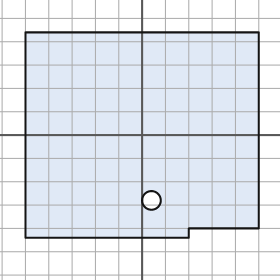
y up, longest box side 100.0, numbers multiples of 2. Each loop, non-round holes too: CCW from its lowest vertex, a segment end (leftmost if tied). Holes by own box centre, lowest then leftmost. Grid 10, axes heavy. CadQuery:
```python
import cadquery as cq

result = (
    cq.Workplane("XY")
    .moveTo(-50.0, -44.0)
    .lineTo(20.0, -44.0)
    .lineTo(20.0, -40.0)
    .lineTo(50.0, -40.0)
    .lineTo(50.0, 44.0)
    .lineTo(-50.0, 44.0)
    .close()
    .moveTo(4.0, -28.0)
    .circle(4.0)
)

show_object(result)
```